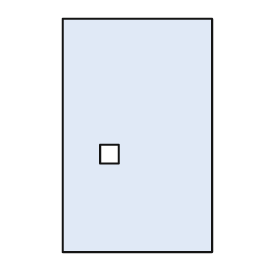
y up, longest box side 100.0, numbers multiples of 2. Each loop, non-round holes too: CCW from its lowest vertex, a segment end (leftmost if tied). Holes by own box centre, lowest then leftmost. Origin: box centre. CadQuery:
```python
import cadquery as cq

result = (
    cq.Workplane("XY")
    .moveTo(-32.0, -50.0)
    .lineTo(32.0, -50.0)
    .lineTo(32.0, 50.0)
    .lineTo(-32.0, 50.0)
    .close()
    .moveTo(-16.0, -12.0)
    .lineTo(-8.0, -12.0)
    .lineTo(-8.0, -4.0)
    .lineTo(-16.0, -4.0)
    .close()
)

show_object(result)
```